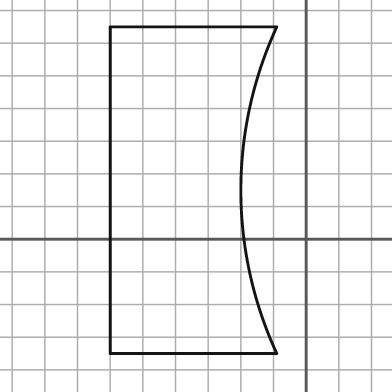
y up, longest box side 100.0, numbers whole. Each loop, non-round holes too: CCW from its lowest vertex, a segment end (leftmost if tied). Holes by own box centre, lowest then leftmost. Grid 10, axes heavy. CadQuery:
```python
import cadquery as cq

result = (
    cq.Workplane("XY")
    .moveTo(-60.0, -35.0)
    .lineTo(-9.0, -35.0)
    .threePointArc((-20.0, 15.0), (-9.0, 65.0))
    .lineTo(-60.0, 65.0)
    .close()
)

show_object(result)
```